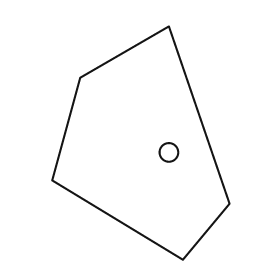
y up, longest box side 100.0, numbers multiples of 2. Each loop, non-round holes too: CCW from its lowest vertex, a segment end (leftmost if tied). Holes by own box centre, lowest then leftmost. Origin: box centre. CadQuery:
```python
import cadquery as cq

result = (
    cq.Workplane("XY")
    .moveTo(18.0, -50.0)
    .lineTo(38.0, -26.0)
    .lineTo(12.0, 50.0)
    .lineTo(-26.0, 28.0)
    .lineTo(-38.0, -16.0)
    .close()
    .moveTo(12.0, -4.0)
    .circle(4.0)
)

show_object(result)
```